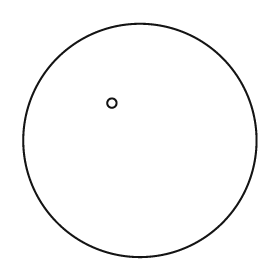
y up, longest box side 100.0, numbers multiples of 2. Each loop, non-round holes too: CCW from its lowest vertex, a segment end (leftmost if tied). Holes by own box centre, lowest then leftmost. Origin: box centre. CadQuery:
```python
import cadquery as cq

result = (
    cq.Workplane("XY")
    .moveTo(0.0, 0.0)
    .circle(50.0)
    .moveTo(-12.0, 16.0)
    .circle(2.0)
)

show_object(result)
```